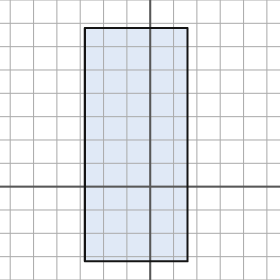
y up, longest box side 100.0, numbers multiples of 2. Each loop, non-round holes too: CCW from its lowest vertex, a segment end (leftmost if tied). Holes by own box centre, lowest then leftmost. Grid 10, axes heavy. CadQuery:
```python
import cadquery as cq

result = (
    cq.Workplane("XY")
    .moveTo(-28.0, -32.0)
    .lineTo(16.0, -32.0)
    .lineTo(16.0, 68.0)
    .lineTo(-28.0, 68.0)
    .close()
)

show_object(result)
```